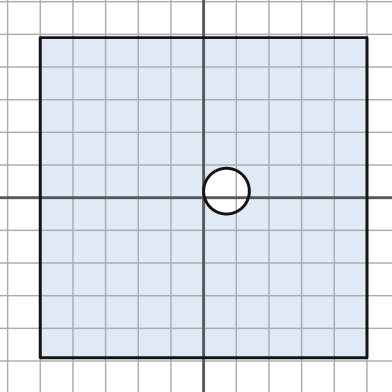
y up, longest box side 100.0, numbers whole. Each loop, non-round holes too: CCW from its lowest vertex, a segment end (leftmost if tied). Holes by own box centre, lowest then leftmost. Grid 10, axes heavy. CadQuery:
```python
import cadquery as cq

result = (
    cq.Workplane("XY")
    .moveTo(-50.0, -49.0)
    .lineTo(50.0, -49.0)
    .lineTo(50.0, 49.0)
    .lineTo(-50.0, 49.0)
    .close()
    .moveTo(7.0, 2.0)
    .circle(7.0)
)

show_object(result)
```